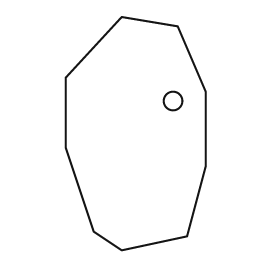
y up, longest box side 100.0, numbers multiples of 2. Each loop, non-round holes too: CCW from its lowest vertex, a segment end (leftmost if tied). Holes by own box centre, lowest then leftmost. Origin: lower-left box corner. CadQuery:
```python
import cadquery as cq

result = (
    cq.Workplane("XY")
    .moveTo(24.0, 0.0)
    .lineTo(52.0, 6.0)
    .lineTo(60.0, 36.0)
    .lineTo(60.0, 68.0)
    .lineTo(48.0, 96.0)
    .lineTo(24.0, 100.0)
    .lineTo(0.0, 74.0)
    .lineTo(0.0, 44.0)
    .lineTo(12.0, 8.0)
    .close()
    .moveTo(46.0, 64.0)
    .circle(4.0)
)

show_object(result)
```